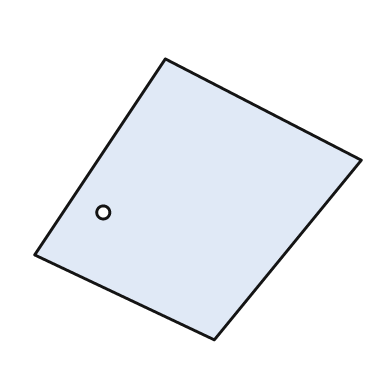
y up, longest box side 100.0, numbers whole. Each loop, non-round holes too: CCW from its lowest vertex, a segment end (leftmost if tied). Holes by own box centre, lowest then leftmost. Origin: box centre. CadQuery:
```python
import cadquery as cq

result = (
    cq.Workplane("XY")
    .moveTo(5.0, -43.0)
    .lineTo(50.0, 12.0)
    .lineTo(-10.0, 43.0)
    .lineTo(-50.0, -17.0)
    .close()
    .moveTo(-29.0, -4.0)
    .circle(2.0)
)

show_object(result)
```